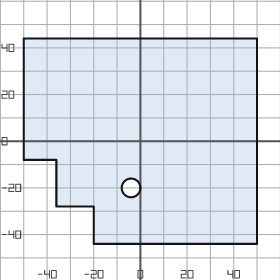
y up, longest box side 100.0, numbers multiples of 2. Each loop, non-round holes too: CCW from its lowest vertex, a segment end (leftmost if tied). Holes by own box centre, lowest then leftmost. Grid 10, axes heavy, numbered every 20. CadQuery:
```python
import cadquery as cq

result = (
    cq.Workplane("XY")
    .moveTo(-20.0, -44.0)
    .lineTo(50.0, -44.0)
    .lineTo(50.0, 44.0)
    .lineTo(-50.0, 44.0)
    .lineTo(-50.0, -8.0)
    .lineTo(-36.0, -8.0)
    .lineTo(-36.0, -28.0)
    .lineTo(-20.0, -28.0)
    .close()
    .moveTo(-4.0, -20.0)
    .circle(4.0)
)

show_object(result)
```